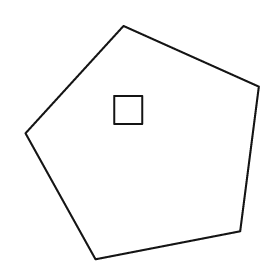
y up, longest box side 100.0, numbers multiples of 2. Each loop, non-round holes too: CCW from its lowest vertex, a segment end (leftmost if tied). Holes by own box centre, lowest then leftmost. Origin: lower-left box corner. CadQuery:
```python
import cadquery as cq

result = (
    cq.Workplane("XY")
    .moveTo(30.0, 0.0)
    .lineTo(92.0, 12.0)
    .lineTo(100.0, 74.0)
    .lineTo(42.0, 100.0)
    .lineTo(0.0, 54.0)
    .close()
    .moveTo(38.0, 58.0)
    .lineTo(50.0, 58.0)
    .lineTo(50.0, 70.0)
    .lineTo(38.0, 70.0)
    .close()
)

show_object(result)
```